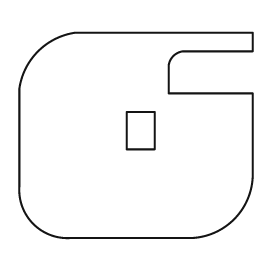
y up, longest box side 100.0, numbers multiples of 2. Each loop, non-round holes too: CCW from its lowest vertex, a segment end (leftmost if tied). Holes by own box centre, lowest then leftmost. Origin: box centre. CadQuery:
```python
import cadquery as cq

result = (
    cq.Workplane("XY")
    .moveTo(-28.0, -44.0)
    .lineTo(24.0, -44.0)
    .threePointArc((42.0, -36.0), (50.0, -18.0))
    .lineTo(50.0, 18.0)
    .lineTo(14.0, 18.0)
    .lineTo(14.0, 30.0)
    .threePointArc((16.0, 34.0), (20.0, 36.0))
    .lineTo(50.0, 36.0)
    .lineTo(50.0, 44.0)
    .lineTo(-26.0, 44.0)
    .threePointArc((-42.0, 36.0), (-50.0, 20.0))
    .lineTo(-50.0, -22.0)
    .threePointArc((-44.0, -38.0), (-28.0, -44.0))
    .close()
    .moveTo(-4.0, -6.0)
    .lineTo(8.0, -6.0)
    .lineTo(8.0, 10.0)
    .lineTo(-4.0, 10.0)
    .close()
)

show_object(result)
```